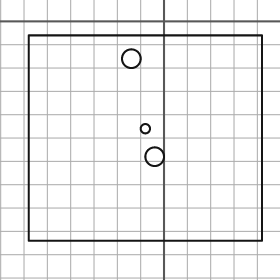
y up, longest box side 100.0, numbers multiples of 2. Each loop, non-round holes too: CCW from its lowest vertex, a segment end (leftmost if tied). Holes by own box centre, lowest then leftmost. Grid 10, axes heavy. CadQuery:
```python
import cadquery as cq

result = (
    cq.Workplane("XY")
    .moveTo(-58.0, -94.0)
    .lineTo(42.0, -94.0)
    .lineTo(42.0, -6.0)
    .lineTo(-58.0, -6.0)
    .close()
    .moveTo(-4.0, -58.0)
    .circle(4.0)
    .moveTo(-8.0, -46.0)
    .circle(2.0)
    .moveTo(-14.0, -16.0)
    .circle(4.0)
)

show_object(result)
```